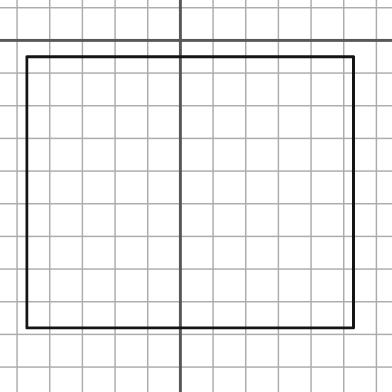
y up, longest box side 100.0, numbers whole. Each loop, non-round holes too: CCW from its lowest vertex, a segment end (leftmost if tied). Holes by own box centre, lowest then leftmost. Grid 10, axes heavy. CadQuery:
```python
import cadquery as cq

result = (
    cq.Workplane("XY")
    .moveTo(-47.0, -88.0)
    .lineTo(53.0, -88.0)
    .lineTo(53.0, -5.0)
    .lineTo(-47.0, -5.0)
    .close()
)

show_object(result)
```